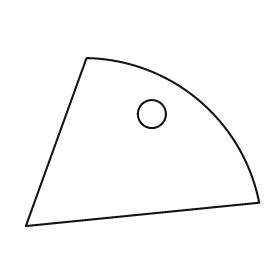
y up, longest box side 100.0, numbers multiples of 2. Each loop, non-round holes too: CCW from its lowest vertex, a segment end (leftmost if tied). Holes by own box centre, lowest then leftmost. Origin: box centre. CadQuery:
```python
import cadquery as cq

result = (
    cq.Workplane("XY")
    .moveTo(-50.0, -36.0)
    .lineTo(50.0, -26.0)
    .threePointArc((24.0, 18.0), (-24.0, 36.0))
    .close()
    .moveTo(4.0, 12.0)
    .circle(6.0)
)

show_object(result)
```